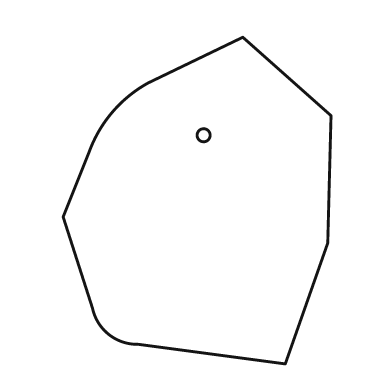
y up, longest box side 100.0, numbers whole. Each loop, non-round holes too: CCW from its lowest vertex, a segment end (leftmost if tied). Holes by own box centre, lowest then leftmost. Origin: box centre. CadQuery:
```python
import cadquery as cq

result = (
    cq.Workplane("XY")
    .moveTo(27.0, -50.0)
    .lineTo(40.0, -13.0)
    .lineTo(41.0, 26.0)
    .lineTo(14.0, 50.0)
    .lineTo(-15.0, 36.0)
    .threePointArc((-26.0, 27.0), (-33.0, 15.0))
    .lineTo(-41.0, -5.0)
    .lineTo(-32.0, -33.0)
    .threePointArc((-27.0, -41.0), (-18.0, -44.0))
    .close()
    .moveTo(2.0, 20.0)
    .circle(2.0)
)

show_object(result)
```